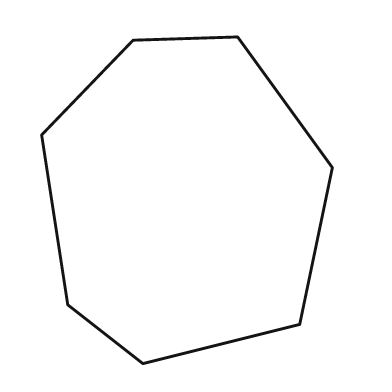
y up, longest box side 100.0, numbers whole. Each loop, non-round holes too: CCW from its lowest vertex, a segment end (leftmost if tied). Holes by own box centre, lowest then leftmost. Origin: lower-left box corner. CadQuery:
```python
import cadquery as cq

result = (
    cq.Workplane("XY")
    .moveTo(31.0, 0.0)
    .lineTo(79.0, 12.0)
    .lineTo(89.0, 60.0)
    .lineTo(60.0, 100.0)
    .lineTo(28.0, 99.0)
    .lineTo(0.0, 70.0)
    .lineTo(8.0, 18.0)
    .close()
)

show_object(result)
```